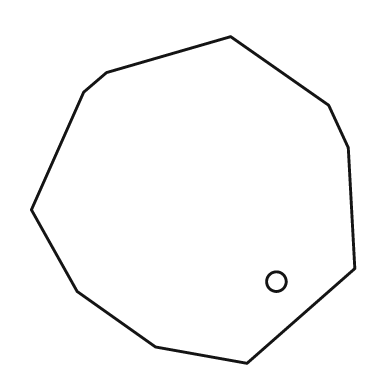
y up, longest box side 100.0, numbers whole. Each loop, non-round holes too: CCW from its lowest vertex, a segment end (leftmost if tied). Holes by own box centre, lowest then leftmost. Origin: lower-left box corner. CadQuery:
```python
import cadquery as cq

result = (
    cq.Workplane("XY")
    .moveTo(66.0, 0.0)
    .lineTo(99.0, 29.0)
    .lineTo(97.0, 66.0)
    .lineTo(91.0, 79.0)
    .lineTo(61.0, 100.0)
    .lineTo(23.0, 89.0)
    .lineTo(16.0, 83.0)
    .lineTo(0.0, 47.0)
    .lineTo(14.0, 22.0)
    .lineTo(38.0, 5.0)
    .close()
    .moveTo(75.0, 25.0)
    .circle(3.0)
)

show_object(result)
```